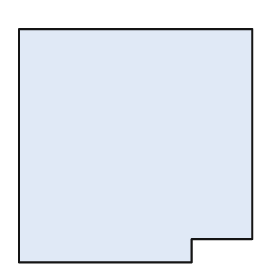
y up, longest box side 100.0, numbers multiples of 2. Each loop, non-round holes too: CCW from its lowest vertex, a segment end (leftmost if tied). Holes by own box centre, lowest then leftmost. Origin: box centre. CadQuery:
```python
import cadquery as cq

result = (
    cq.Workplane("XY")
    .moveTo(-50.0, -50.0)
    .lineTo(24.0, -50.0)
    .lineTo(24.0, -40.0)
    .lineTo(50.0, -40.0)
    .lineTo(50.0, 50.0)
    .lineTo(-50.0, 50.0)
    .close()
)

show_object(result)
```